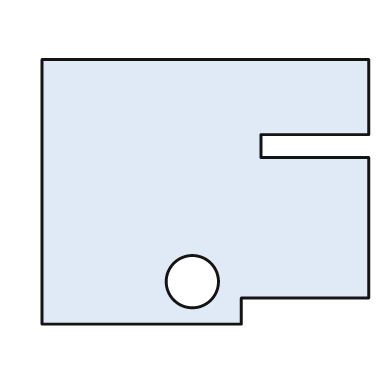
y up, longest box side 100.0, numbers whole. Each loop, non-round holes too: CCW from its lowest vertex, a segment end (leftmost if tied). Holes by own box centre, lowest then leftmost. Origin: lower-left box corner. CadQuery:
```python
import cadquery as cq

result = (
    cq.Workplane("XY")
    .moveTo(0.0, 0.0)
    .lineTo(61.0, 0.0)
    .lineTo(61.0, 8.0)
    .lineTo(100.0, 8.0)
    .lineTo(100.0, 51.0)
    .lineTo(67.0, 51.0)
    .lineTo(67.0, 58.0)
    .lineTo(100.0, 58.0)
    .lineTo(100.0, 81.0)
    .lineTo(0.0, 81.0)
    .close()
    .moveTo(46.0, 13.0)
    .circle(8.0)
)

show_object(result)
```